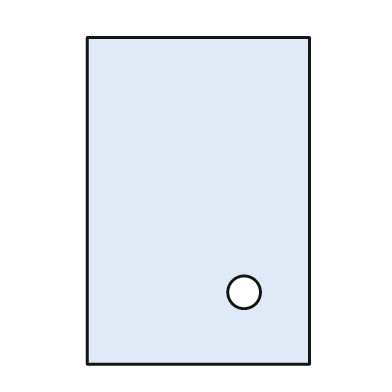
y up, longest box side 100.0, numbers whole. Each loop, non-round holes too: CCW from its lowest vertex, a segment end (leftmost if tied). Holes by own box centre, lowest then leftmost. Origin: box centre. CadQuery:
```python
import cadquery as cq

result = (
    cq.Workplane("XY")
    .moveTo(-34.0, -50.0)
    .lineTo(34.0, -50.0)
    .lineTo(34.0, 50.0)
    .lineTo(-34.0, 50.0)
    .close()
    .moveTo(14.0, -28.0)
    .circle(5.0)
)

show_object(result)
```